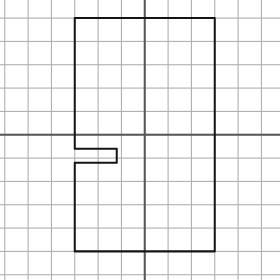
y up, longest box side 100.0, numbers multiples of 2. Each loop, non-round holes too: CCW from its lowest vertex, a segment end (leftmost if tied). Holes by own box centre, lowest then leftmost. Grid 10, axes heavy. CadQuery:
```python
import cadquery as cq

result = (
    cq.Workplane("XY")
    .moveTo(-30.0, -50.0)
    .lineTo(30.0, -50.0)
    .lineTo(30.0, 50.0)
    .lineTo(-30.0, 50.0)
    .lineTo(-30.0, -6.0)
    .lineTo(-12.0, -6.0)
    .lineTo(-12.0, -12.0)
    .lineTo(-30.0, -12.0)
    .close()
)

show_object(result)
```